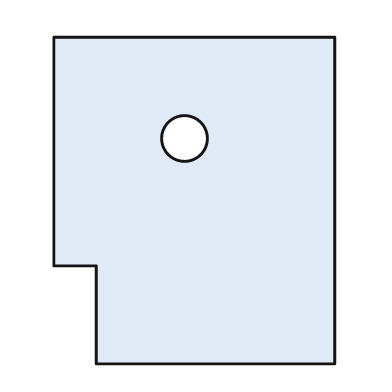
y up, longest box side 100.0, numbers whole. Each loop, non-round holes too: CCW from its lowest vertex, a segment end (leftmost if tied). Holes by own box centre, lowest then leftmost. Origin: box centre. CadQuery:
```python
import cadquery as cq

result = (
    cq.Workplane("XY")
    .moveTo(-30.0, -50.0)
    .lineTo(43.0, -50.0)
    .lineTo(43.0, 50.0)
    .lineTo(-43.0, 50.0)
    .lineTo(-43.0, -20.0)
    .lineTo(-30.0, -20.0)
    .close()
    .moveTo(-3.0, 19.0)
    .circle(7.0)
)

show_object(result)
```